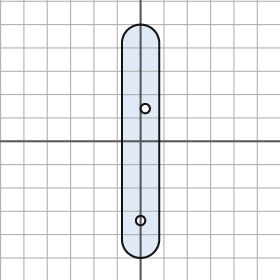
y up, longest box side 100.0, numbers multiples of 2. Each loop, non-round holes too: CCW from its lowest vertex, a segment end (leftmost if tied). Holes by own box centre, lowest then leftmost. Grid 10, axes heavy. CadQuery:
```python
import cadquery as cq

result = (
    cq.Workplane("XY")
    .moveTo(-8.0, -42.0)
    .threePointArc((0.0, -50.0), (8.0, -42.0))
    .lineTo(8.0, 42.0)
    .threePointArc((0.0, 50.0), (-8.0, 42.0))
    .close()
    .moveTo(0.0, -34.0)
    .circle(2.0)
    .moveTo(2.0, 14.0)
    .circle(2.0)
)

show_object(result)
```